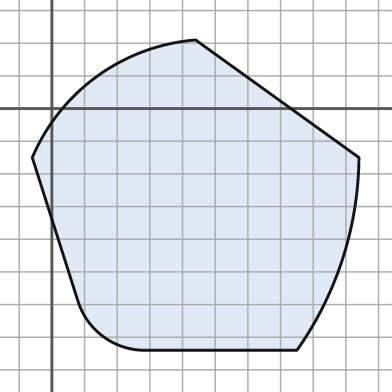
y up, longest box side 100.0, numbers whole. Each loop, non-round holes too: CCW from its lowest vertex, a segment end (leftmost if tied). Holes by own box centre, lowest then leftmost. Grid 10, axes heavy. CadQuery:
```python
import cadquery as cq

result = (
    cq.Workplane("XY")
    .moveTo(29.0, -74.0)
    .lineTo(75.0, -74.0)
    .threePointArc((89.0, -46.0), (94.0, -15.0))
    .lineTo(44.0, 21.0)
    .threePointArc((14.0, 10.0), (-6.0, -15.0))
    .lineTo(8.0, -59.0)
    .threePointArc((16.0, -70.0), (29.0, -74.0))
    .close()
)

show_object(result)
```